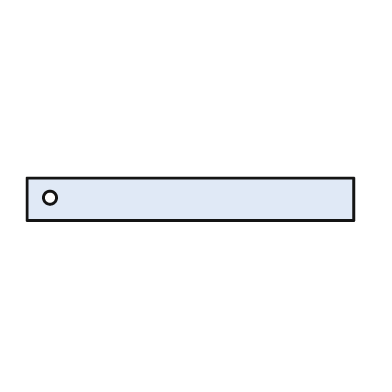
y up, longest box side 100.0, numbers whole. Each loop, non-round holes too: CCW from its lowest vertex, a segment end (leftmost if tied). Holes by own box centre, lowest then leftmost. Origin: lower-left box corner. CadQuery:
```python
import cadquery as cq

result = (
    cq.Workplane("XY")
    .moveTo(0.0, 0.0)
    .lineTo(100.0, 0.0)
    .lineTo(100.0, 13.0)
    .lineTo(0.0, 13.0)
    .close()
    .moveTo(7.0, 7.0)
    .circle(2.0)
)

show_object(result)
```